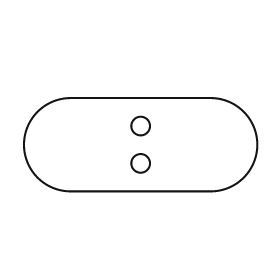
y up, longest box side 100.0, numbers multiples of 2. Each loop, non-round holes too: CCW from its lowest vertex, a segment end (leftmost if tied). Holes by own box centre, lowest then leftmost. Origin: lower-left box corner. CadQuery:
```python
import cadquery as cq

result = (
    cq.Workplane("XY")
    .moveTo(20.0, 0.0)
    .lineTo(80.0, 0.0)
    .threePointArc((100.0, 20.0), (80.0, 40.0))
    .lineTo(20.0, 40.0)
    .threePointArc((0.0, 20.0), (20.0, 0.0))
    .close()
    .moveTo(50.0, 12.0)
    .circle(4.0)
    .moveTo(50.0, 28.0)
    .circle(4.0)
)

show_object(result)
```